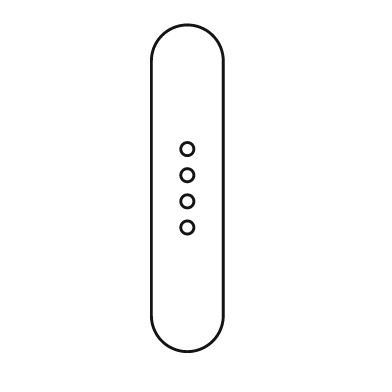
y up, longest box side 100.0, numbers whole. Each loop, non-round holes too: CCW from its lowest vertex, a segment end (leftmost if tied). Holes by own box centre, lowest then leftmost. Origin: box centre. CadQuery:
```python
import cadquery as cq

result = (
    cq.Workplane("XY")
    .moveTo(-11.0, -39.0)
    .threePointArc((0.0, -50.0), (11.0, -39.0))
    .lineTo(11.0, 39.0)
    .threePointArc((0.0, 50.0), (-11.0, 39.0))
    .close()
    .moveTo(0.0, -12.0)
    .circle(2.0)
    .moveTo(0.0, -4.0)
    .circle(2.0)
    .moveTo(0.0, 4.0)
    .circle(2.0)
    .moveTo(0.0, 12.0)
    .circle(2.0)
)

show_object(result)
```